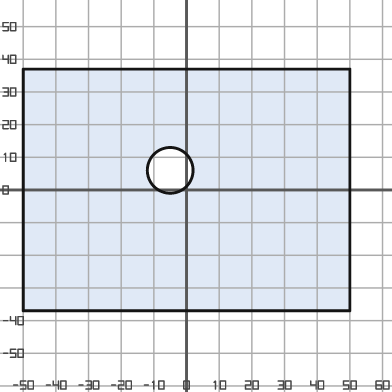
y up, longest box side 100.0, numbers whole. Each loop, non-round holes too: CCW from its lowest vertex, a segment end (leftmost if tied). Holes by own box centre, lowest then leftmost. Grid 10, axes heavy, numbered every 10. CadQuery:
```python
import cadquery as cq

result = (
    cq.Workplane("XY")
    .moveTo(-50.0, -37.0)
    .lineTo(50.0, -37.0)
    .lineTo(50.0, 37.0)
    .lineTo(-50.0, 37.0)
    .close()
    .moveTo(-5.0, 6.0)
    .circle(7.0)
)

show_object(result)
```